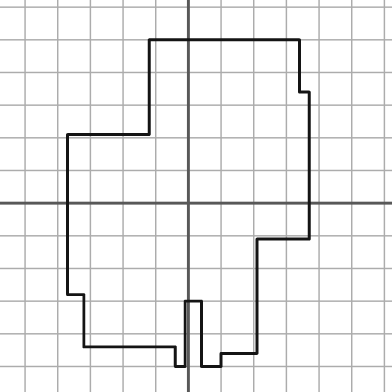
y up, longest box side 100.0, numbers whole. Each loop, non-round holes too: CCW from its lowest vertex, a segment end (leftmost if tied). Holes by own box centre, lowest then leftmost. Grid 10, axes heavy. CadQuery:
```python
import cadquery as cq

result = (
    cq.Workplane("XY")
    .moveTo(-4.0, -50.0)
    .lineTo(-1.0, -50.0)
    .lineTo(-1.0, -30.0)
    .lineTo(4.0, -30.0)
    .lineTo(4.0, -50.0)
    .lineTo(10.0, -50.0)
    .lineTo(10.0, -46.0)
    .lineTo(21.0, -46.0)
    .lineTo(21.0, -11.0)
    .lineTo(37.0, -11.0)
    .lineTo(37.0, 34.0)
    .lineTo(34.0, 34.0)
    .lineTo(34.0, 50.0)
    .lineTo(-12.0, 50.0)
    .lineTo(-12.0, 21.0)
    .lineTo(-37.0, 21.0)
    .lineTo(-37.0, -28.0)
    .lineTo(-32.0, -28.0)
    .lineTo(-32.0, -44.0)
    .lineTo(-4.0, -44.0)
    .close()
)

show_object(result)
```